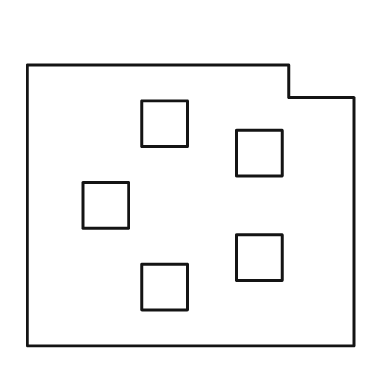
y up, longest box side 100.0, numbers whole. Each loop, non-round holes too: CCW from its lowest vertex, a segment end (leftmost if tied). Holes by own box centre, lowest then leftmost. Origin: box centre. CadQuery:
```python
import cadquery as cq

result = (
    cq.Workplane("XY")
    .moveTo(-50.0, -43.0)
    .lineTo(50.0, -43.0)
    .lineTo(50.0, 33.0)
    .lineTo(30.0, 33.0)
    .lineTo(30.0, 43.0)
    .lineTo(-50.0, 43.0)
    .close()
    .moveTo(-15.0, -32.0)
    .lineTo(-1.0, -32.0)
    .lineTo(-1.0, -18.0)
    .lineTo(-15.0, -18.0)
    .close()
    .moveTo(14.0, -23.0)
    .lineTo(28.0, -23.0)
    .lineTo(28.0, -9.0)
    .lineTo(14.0, -9.0)
    .close()
    .moveTo(-33.0, -7.0)
    .lineTo(-19.0, -7.0)
    .lineTo(-19.0, 7.0)
    .lineTo(-33.0, 7.0)
    .close()
    .moveTo(14.0, 9.0)
    .lineTo(28.0, 9.0)
    .lineTo(28.0, 23.0)
    .lineTo(14.0, 23.0)
    .close()
    .moveTo(-15.0, 18.0)
    .lineTo(-1.0, 18.0)
    .lineTo(-1.0, 32.0)
    .lineTo(-15.0, 32.0)
    .close()
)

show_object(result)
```